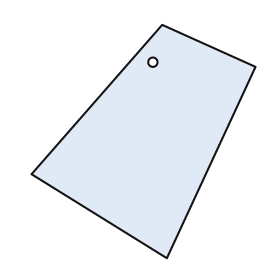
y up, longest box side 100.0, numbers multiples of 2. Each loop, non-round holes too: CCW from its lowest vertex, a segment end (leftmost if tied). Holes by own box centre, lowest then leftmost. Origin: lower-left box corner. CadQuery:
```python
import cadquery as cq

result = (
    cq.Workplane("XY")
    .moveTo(58.0, 0.0)
    .lineTo(96.0, 82.0)
    .lineTo(56.0, 100.0)
    .lineTo(0.0, 36.0)
    .close()
    .moveTo(52.0, 84.0)
    .circle(2.0)
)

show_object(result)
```